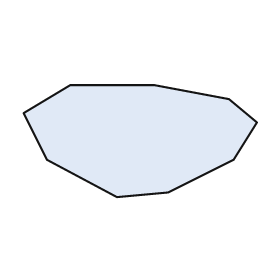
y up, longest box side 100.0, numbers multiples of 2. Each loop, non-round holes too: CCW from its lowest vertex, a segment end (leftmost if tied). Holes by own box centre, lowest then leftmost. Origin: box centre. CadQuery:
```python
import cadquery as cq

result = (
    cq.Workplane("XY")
    .moveTo(-10.0, -24.0)
    .lineTo(12.0, -22.0)
    .lineTo(40.0, -8.0)
    .lineTo(50.0, 8.0)
    .lineTo(38.0, 18.0)
    .lineTo(6.0, 24.0)
    .lineTo(-30.0, 24.0)
    .lineTo(-50.0, 12.0)
    .lineTo(-40.0, -8.0)
    .close()
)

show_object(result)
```